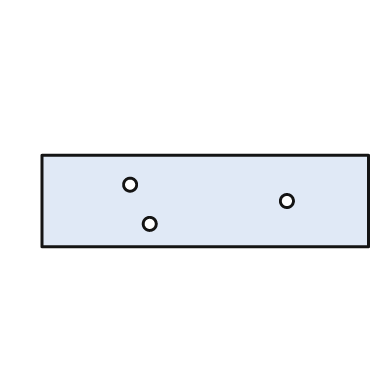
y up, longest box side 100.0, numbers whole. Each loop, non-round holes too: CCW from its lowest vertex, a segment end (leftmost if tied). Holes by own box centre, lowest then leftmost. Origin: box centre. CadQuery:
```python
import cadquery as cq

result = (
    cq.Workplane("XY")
    .moveTo(-50.0, -14.0)
    .lineTo(50.0, -14.0)
    .lineTo(50.0, 14.0)
    .lineTo(-50.0, 14.0)
    .close()
    .moveTo(-17.0, -7.0)
    .circle(2.0)
    .moveTo(25.0, 0.0)
    .circle(2.0)
    .moveTo(-23.0, 5.0)
    .circle(2.0)
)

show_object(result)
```